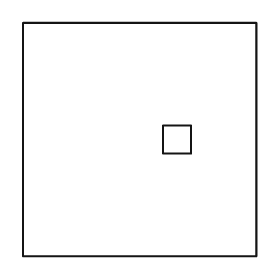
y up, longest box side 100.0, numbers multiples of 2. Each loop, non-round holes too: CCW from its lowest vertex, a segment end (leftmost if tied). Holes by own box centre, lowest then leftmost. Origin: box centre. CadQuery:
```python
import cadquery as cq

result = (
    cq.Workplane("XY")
    .moveTo(-50.0, -50.0)
    .lineTo(50.0, -50.0)
    .lineTo(50.0, 50.0)
    .lineTo(-50.0, 50.0)
    .close()
    .moveTo(10.0, -6.0)
    .lineTo(22.0, -6.0)
    .lineTo(22.0, 6.0)
    .lineTo(10.0, 6.0)
    .close()
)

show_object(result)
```